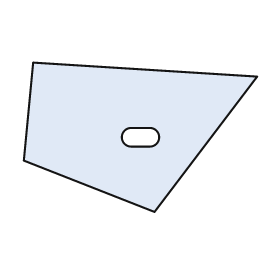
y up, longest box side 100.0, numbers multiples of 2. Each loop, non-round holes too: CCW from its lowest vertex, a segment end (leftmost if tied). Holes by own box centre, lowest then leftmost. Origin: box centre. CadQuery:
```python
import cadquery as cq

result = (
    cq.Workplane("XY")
    .moveTo(6.0, -32.0)
    .lineTo(50.0, 26.0)
    .lineTo(-46.0, 32.0)
    .lineTo(-50.0, -10.0)
    .close()
    .moveTo(-4.0, -4.0)
    .lineTo(4.0, -4.0)
    .threePointArc((8.0, 0.0), (4.0, 4.0))
    .lineTo(-4.0, 4.0)
    .threePointArc((-8.0, 0.0), (-4.0, -4.0))
    .close()
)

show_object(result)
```